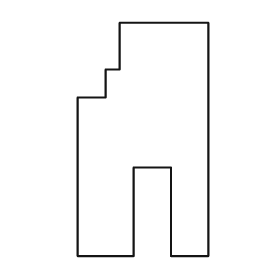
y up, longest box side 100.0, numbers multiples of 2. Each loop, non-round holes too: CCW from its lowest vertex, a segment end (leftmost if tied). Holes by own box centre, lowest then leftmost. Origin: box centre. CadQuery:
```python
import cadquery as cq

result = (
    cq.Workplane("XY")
    .moveTo(-28.0, -50.0)
    .lineTo(-4.0, -50.0)
    .lineTo(-4.0, -12.0)
    .lineTo(12.0, -12.0)
    .lineTo(12.0, -50.0)
    .lineTo(28.0, -50.0)
    .lineTo(28.0, 50.0)
    .lineTo(-10.0, 50.0)
    .lineTo(-10.0, 30.0)
    .lineTo(-16.0, 30.0)
    .lineTo(-16.0, 18.0)
    .lineTo(-28.0, 18.0)
    .close()
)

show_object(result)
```